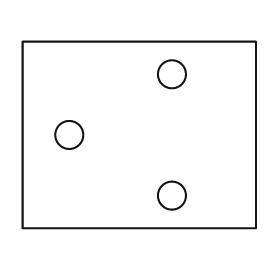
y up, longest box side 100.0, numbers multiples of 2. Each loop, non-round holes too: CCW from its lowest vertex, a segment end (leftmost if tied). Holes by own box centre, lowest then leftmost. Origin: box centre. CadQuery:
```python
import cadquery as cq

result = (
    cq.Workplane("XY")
    .moveTo(-50.0, -40.0)
    .lineTo(50.0, -40.0)
    .lineTo(50.0, 40.0)
    .lineTo(-50.0, 40.0)
    .close()
    .moveTo(14.0, -26.0)
    .circle(6.0)
    .moveTo(-30.0, 0.0)
    .circle(6.0)
    .moveTo(14.0, 26.0)
    .circle(6.0)
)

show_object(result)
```